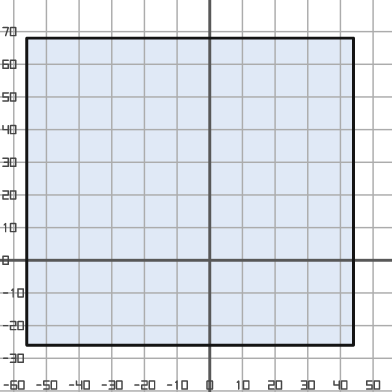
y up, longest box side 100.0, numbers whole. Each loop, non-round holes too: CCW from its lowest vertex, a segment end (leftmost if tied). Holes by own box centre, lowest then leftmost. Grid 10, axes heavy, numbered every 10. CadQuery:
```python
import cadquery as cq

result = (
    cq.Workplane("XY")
    .moveTo(-56.0, -26.0)
    .lineTo(44.0, -26.0)
    .lineTo(44.0, 68.0)
    .lineTo(-56.0, 68.0)
    .close()
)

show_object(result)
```